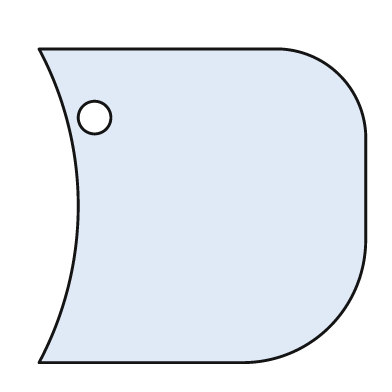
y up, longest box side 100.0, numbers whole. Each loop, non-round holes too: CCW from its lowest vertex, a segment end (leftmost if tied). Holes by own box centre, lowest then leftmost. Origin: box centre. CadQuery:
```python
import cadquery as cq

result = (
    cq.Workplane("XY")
    .moveTo(-50.0, -48.0)
    .lineTo(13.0, -48.0)
    .threePointArc((39.0, -37.0), (50.0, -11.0))
    .lineTo(50.0, 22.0)
    .threePointArc((42.0, 40.0), (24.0, 48.0))
    .lineTo(-50.0, 48.0)
    .threePointArc((-38.0, 0.0), (-50.0, -48.0))
    .close()
    .moveTo(-33.0, 27.0)
    .circle(5.0)
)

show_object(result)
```